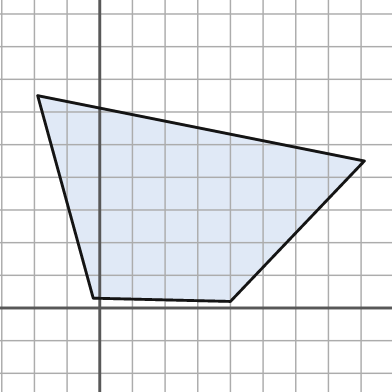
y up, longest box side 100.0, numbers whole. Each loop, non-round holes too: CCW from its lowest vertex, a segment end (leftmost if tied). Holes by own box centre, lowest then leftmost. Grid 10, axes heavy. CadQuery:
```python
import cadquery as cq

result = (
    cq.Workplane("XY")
    .moveTo(40.0, 2.0)
    .lineTo(81.0, 45.0)
    .lineTo(-19.0, 65.0)
    .lineTo(-2.0, 3.0)
    .close()
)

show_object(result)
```